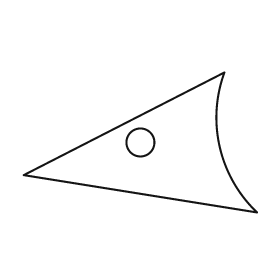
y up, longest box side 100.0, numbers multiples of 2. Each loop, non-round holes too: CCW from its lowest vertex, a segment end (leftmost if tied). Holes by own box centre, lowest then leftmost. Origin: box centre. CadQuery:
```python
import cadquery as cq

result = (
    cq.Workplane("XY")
    .moveTo(50.0, -30.0)
    .threePointArc((34.0, -2.0), (36.0, 30.0))
    .lineTo(-50.0, -14.0)
    .close()
    .moveTo(0.0, 0.0)
    .circle(6.0)
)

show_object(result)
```